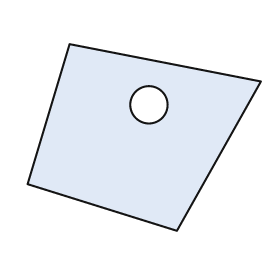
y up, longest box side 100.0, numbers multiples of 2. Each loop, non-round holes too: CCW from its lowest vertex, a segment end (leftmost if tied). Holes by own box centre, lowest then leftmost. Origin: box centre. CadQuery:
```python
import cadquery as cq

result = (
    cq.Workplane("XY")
    .moveTo(14.0, -40.0)
    .lineTo(50.0, 24.0)
    .lineTo(-32.0, 40.0)
    .lineTo(-50.0, -20.0)
    .close()
    .moveTo(2.0, 14.0)
    .circle(8.0)
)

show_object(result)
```